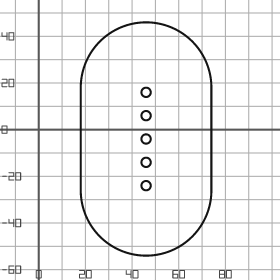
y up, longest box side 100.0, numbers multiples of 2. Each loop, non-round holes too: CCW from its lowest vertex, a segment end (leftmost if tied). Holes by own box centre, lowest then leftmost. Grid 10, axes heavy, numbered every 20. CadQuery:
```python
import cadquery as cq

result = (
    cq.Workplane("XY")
    .moveTo(18.0, -26.0)
    .threePointArc((46.0, -54.0), (74.0, -26.0))
    .lineTo(74.0, 18.0)
    .threePointArc((46.0, 46.0), (18.0, 18.0))
    .close()
    .moveTo(46.0, -24.0)
    .circle(2.0)
    .moveTo(46.0, -14.0)
    .circle(2.0)
    .moveTo(46.0, -4.0)
    .circle(2.0)
    .moveTo(46.0, 6.0)
    .circle(2.0)
    .moveTo(46.0, 16.0)
    .circle(2.0)
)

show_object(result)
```